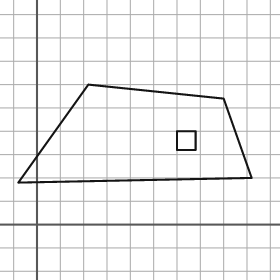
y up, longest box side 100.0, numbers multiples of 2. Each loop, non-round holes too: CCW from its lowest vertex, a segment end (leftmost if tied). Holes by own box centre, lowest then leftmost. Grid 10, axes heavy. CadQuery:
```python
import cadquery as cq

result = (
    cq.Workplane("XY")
    .moveTo(-8.0, 18.0)
    .lineTo(92.0, 20.0)
    .lineTo(80.0, 54.0)
    .lineTo(22.0, 60.0)
    .close()
    .moveTo(60.0, 32.0)
    .lineTo(68.0, 32.0)
    .lineTo(68.0, 40.0)
    .lineTo(60.0, 40.0)
    .close()
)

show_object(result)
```